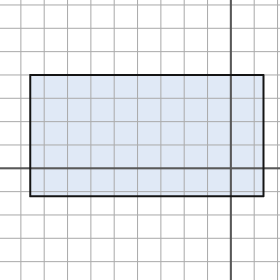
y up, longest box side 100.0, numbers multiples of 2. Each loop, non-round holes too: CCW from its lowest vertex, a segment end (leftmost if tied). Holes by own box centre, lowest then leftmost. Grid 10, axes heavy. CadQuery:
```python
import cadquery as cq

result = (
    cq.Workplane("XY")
    .moveTo(-86.0, -12.0)
    .lineTo(14.0, -12.0)
    .lineTo(14.0, 40.0)
    .lineTo(-86.0, 40.0)
    .close()
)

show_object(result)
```